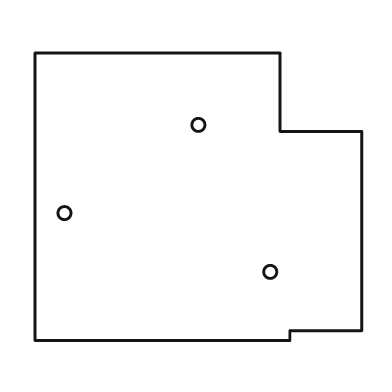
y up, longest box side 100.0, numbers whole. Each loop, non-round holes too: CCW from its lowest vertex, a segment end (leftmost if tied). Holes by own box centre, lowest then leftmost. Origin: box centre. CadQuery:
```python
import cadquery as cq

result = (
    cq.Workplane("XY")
    .moveTo(-50.0, -44.0)
    .lineTo(28.0, -44.0)
    .lineTo(28.0, -41.0)
    .lineTo(50.0, -41.0)
    .lineTo(50.0, 20.0)
    .lineTo(25.0, 20.0)
    .lineTo(25.0, 44.0)
    .lineTo(-50.0, 44.0)
    .close()
    .moveTo(22.0, -23.0)
    .circle(2.0)
    .moveTo(-41.0, -5.0)
    .circle(2.0)
    .moveTo(0.0, 22.0)
    .circle(2.0)
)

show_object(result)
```